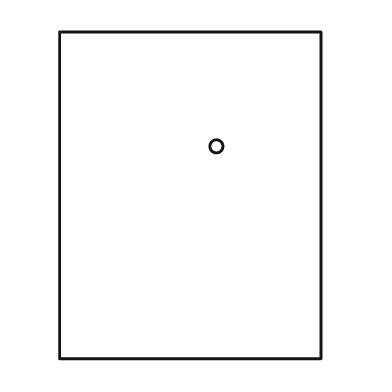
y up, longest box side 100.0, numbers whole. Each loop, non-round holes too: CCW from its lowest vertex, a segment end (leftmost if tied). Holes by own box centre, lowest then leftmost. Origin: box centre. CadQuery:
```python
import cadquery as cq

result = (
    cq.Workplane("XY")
    .moveTo(-40.0, -50.0)
    .lineTo(40.0, -50.0)
    .lineTo(40.0, 50.0)
    .lineTo(-40.0, 50.0)
    .close()
    .moveTo(8.0, 15.0)
    .circle(2.0)
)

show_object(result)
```